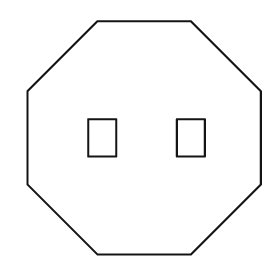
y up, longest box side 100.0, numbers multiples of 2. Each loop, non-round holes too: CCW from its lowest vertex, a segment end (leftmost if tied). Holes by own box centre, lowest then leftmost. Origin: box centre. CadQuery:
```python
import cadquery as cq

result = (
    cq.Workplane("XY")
    .moveTo(-20.0, -50.0)
    .lineTo(20.0, -50.0)
    .lineTo(50.0, -20.0)
    .lineTo(50.0, 20.0)
    .lineTo(20.0, 50.0)
    .lineTo(-20.0, 50.0)
    .lineTo(-50.0, 20.0)
    .lineTo(-50.0, -20.0)
    .close()
    .moveTo(-24.0, -8.0)
    .lineTo(-12.0, -8.0)
    .lineTo(-12.0, 8.0)
    .lineTo(-24.0, 8.0)
    .close()
    .moveTo(14.0, -8.0)
    .lineTo(26.0, -8.0)
    .lineTo(26.0, 8.0)
    .lineTo(14.0, 8.0)
    .close()
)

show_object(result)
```